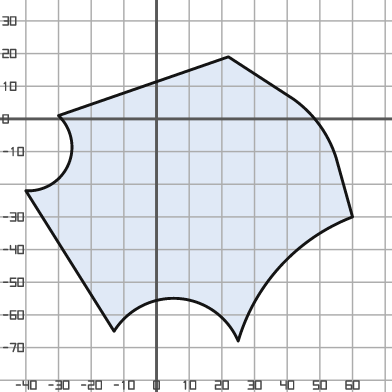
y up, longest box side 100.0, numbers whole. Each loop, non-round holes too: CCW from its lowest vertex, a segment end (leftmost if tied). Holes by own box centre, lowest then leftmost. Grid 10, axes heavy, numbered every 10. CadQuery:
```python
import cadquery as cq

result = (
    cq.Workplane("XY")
    .moveTo(25.0, -68.0)
    .threePointArc((38.0, -45.0), (60.0, -30.0))
    .lineTo(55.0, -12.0)
    .threePointArc((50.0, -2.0), (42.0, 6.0))
    .lineTo(22.0, 19.0)
    .lineTo(-30.0, 1.0)
    .threePointArc((-27.0, -14.0), (-40.0, -22.0))
    .lineTo(-13.0, -65.0)
    .threePointArc((7.0, -55.0), (25.0, -68.0))
    .close()
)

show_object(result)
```